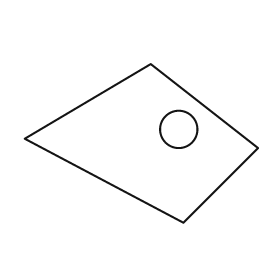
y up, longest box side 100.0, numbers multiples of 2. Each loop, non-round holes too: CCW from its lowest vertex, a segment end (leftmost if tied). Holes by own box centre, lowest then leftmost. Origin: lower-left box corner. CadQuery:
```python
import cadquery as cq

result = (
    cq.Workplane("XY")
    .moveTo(68.0, 0.0)
    .lineTo(100.0, 32.0)
    .lineTo(54.0, 68.0)
    .lineTo(0.0, 36.0)
    .close()
    .moveTo(66.0, 40.0)
    .circle(8.0)
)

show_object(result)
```